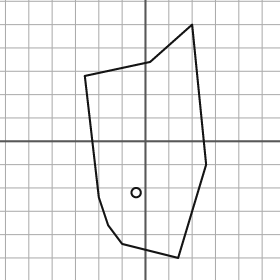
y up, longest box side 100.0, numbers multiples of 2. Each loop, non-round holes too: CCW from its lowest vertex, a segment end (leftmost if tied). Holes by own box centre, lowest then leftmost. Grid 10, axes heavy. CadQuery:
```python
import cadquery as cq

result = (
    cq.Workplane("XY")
    .moveTo(14.0, -50.0)
    .lineTo(26.0, -10.0)
    .lineTo(20.0, 50.0)
    .lineTo(2.0, 34.0)
    .lineTo(-26.0, 28.0)
    .lineTo(-20.0, -24.0)
    .lineTo(-16.0, -36.0)
    .lineTo(-10.0, -44.0)
    .close()
    .moveTo(-4.0, -22.0)
    .circle(2.0)
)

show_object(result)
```